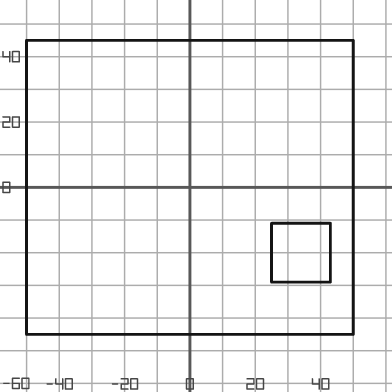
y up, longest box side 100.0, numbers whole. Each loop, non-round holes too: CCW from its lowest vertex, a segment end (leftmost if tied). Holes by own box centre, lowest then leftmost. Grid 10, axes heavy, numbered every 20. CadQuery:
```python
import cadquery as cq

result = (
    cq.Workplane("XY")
    .moveTo(-50.0, -45.0)
    .lineTo(50.0, -45.0)
    .lineTo(50.0, 45.0)
    .lineTo(-50.0, 45.0)
    .close()
    .moveTo(25.0, -29.0)
    .lineTo(43.0, -29.0)
    .lineTo(43.0, -11.0)
    .lineTo(25.0, -11.0)
    .close()
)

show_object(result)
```